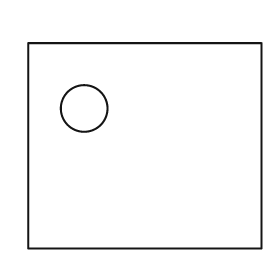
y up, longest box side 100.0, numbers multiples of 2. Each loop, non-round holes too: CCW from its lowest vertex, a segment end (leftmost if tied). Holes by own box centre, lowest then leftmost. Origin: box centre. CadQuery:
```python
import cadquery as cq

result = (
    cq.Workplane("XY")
    .moveTo(-50.0, -44.0)
    .lineTo(50.0, -44.0)
    .lineTo(50.0, 44.0)
    .lineTo(-50.0, 44.0)
    .close()
    .moveTo(-26.0, 16.0)
    .circle(10.0)
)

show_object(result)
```